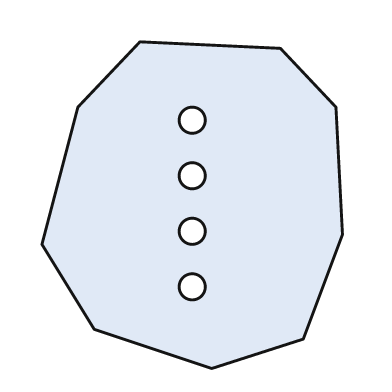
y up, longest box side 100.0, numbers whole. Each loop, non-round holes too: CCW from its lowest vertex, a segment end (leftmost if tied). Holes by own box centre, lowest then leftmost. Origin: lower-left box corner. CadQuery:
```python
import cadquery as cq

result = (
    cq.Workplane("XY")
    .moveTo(52.0, 0.0)
    .lineTo(80.0, 9.0)
    .lineTo(92.0, 41.0)
    .lineTo(90.0, 80.0)
    .lineTo(73.0, 98.0)
    .lineTo(30.0, 100.0)
    .lineTo(11.0, 80.0)
    .lineTo(0.0, 38.0)
    .lineTo(16.0, 12.0)
    .close()
    .moveTo(46.0, 25.0)
    .circle(4.0)
    .moveTo(46.0, 42.0)
    .circle(4.0)
    .moveTo(46.0, 59.0)
    .circle(4.0)
    .moveTo(46.0, 76.0)
    .circle(4.0)
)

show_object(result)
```